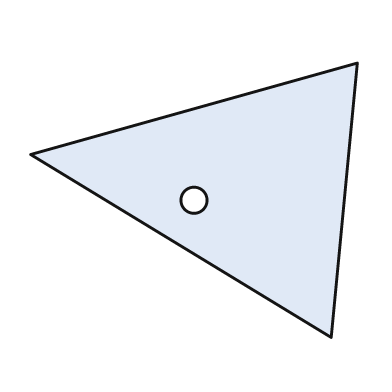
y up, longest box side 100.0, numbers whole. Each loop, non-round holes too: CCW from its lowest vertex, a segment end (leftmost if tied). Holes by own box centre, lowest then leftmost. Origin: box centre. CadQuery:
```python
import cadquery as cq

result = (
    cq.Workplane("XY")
    .moveTo(42.0, -42.0)
    .lineTo(50.0, 42.0)
    .lineTo(-50.0, 14.0)
    .close()
    .moveTo(0.0, 0.0)
    .circle(4.0)
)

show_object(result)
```